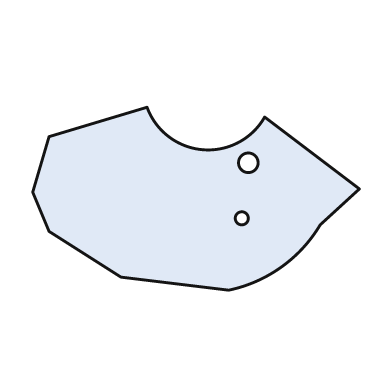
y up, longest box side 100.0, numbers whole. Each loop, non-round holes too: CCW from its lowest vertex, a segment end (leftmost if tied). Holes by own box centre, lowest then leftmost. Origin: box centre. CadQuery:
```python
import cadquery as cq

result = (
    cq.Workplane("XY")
    .moveTo(10.0, -28.0)
    .threePointArc((26.0, -21.0), (38.0, -8.0))
    .lineTo(50.0, 3.0)
    .lineTo(21.0, 25.0)
    .threePointArc((2.0, 15.0), (-15.0, 28.0))
    .lineTo(-45.0, 19.0)
    .lineTo(-50.0, 2.0)
    .lineTo(-45.0, -10.0)
    .lineTo(-23.0, -24.0)
    .close()
    .moveTo(14.0, -6.0)
    .circle(2.0)
    .moveTo(16.0, 11.0)
    .circle(3.0)
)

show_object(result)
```